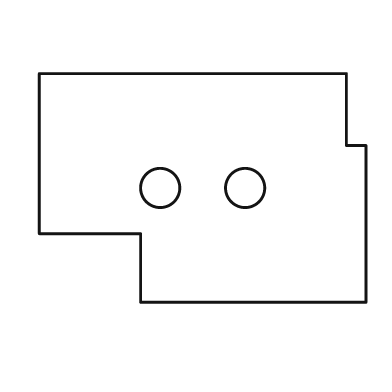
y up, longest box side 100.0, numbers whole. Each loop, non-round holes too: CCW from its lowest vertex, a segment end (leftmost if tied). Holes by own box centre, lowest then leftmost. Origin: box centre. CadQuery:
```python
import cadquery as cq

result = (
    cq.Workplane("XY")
    .moveTo(-19.0, -35.0)
    .lineTo(50.0, -35.0)
    .lineTo(50.0, 13.0)
    .lineTo(44.0, 13.0)
    .lineTo(44.0, 35.0)
    .lineTo(-50.0, 35.0)
    .lineTo(-50.0, -14.0)
    .lineTo(-19.0, -14.0)
    .close()
    .moveTo(-13.0, 0.0)
    .circle(6.0)
    .moveTo(13.0, 0.0)
    .circle(6.0)
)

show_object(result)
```